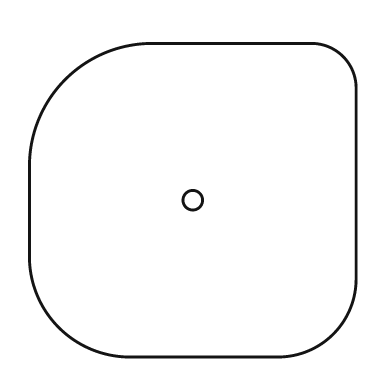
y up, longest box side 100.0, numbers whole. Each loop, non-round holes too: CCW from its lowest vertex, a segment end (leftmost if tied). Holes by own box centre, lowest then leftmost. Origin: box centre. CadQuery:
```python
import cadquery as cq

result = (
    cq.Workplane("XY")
    .moveTo(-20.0, -48.0)
    .lineTo(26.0, -48.0)
    .threePointArc((43.0, -41.0), (50.0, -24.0))
    .lineTo(50.0, 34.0)
    .threePointArc((46.0, 44.0), (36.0, 48.0))
    .lineTo(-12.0, 48.0)
    .threePointArc((-39.0, 37.0), (-50.0, 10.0))
    .lineTo(-50.0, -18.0)
    .threePointArc((-41.0, -39.0), (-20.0, -48.0))
    .close()
    .moveTo(0.0, 0.0)
    .circle(3.0)
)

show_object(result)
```